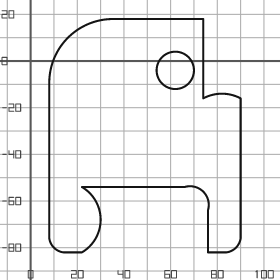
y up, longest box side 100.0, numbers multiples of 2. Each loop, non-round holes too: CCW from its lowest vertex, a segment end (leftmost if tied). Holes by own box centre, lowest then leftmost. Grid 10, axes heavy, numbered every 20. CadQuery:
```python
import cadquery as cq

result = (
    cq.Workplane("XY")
    .moveTo(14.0, -82.0)
    .lineTo(22.0, -82.0)
    .threePointArc((30.0, -68.0), (22.0, -54.0))
    .lineTo(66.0, -54.0)
    .threePointArc((74.0, -56.0), (76.0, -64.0))
    .lineTo(76.0, -82.0)
    .lineTo(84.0, -82.0)
    .threePointArc((88.0, -80.0), (90.0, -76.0))
    .lineTo(90.0, -16.0)
    .threePointArc((82.0, -14.0), (74.0, -16.0))
    .lineTo(74.0, 18.0)
    .lineTo(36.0, 18.0)
    .threePointArc((16.0, 10.0), (8.0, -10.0))
    .lineTo(8.0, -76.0)
    .threePointArc((10.0, -80.0), (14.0, -82.0))
    .close()
    .moveTo(62.0, -4.0)
    .circle(8.0)
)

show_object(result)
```